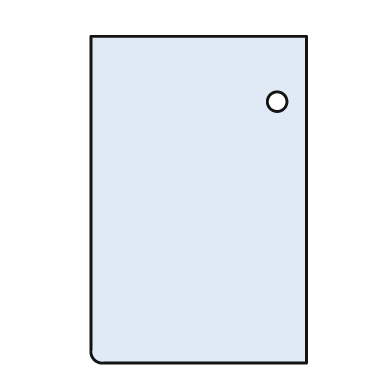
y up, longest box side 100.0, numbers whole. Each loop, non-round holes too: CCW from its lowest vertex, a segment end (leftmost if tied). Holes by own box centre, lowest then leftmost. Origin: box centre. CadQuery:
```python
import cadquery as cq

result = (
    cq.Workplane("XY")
    .moveTo(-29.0, -50.0)
    .lineTo(33.0, -50.0)
    .lineTo(33.0, 50.0)
    .lineTo(-33.0, 50.0)
    .lineTo(-33.0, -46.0)
    .threePointArc((-32.0, -49.0), (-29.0, -50.0))
    .close()
    .moveTo(24.0, 30.0)
    .circle(3.0)
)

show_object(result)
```